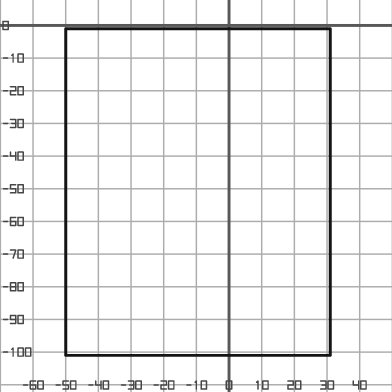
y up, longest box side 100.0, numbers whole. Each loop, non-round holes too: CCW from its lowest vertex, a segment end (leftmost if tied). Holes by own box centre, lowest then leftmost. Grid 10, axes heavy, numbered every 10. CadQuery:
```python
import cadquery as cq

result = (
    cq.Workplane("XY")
    .moveTo(-50.0, -101.0)
    .lineTo(31.0, -101.0)
    .lineTo(31.0, -1.0)
    .lineTo(-50.0, -1.0)
    .close()
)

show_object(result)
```